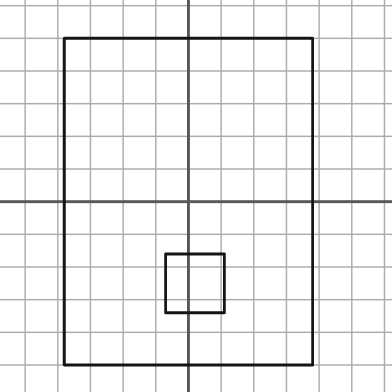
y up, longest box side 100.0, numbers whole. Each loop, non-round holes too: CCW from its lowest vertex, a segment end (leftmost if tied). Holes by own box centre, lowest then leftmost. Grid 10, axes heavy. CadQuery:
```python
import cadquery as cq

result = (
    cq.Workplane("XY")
    .moveTo(-38.0, -50.0)
    .lineTo(38.0, -50.0)
    .lineTo(38.0, 50.0)
    .lineTo(-38.0, 50.0)
    .close()
    .moveTo(-7.0, -34.0)
    .lineTo(11.0, -34.0)
    .lineTo(11.0, -16.0)
    .lineTo(-7.0, -16.0)
    .close()
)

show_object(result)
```